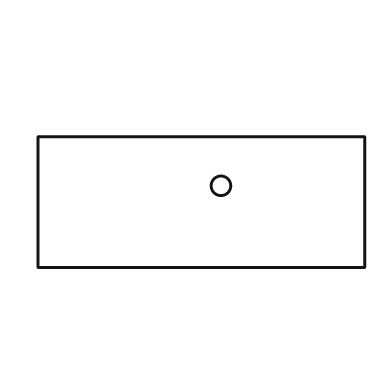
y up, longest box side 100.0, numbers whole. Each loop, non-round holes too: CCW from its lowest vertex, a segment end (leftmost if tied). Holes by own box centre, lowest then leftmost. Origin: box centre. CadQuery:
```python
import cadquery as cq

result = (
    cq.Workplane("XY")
    .moveTo(-50.0, -20.0)
    .lineTo(50.0, -20.0)
    .lineTo(50.0, 20.0)
    .lineTo(-50.0, 20.0)
    .close()
    .moveTo(6.0, 5.0)
    .circle(3.0)
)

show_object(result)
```